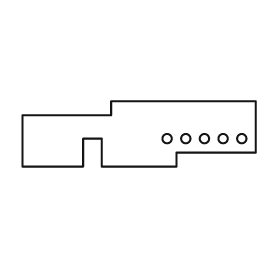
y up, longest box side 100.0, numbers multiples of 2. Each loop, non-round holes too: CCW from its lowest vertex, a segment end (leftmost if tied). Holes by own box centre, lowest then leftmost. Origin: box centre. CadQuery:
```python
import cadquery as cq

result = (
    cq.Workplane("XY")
    .moveTo(-50.0, -14.0)
    .lineTo(-24.0, -14.0)
    .lineTo(-24.0, -2.0)
    .lineTo(-16.0, -2.0)
    .lineTo(-16.0, -14.0)
    .lineTo(16.0, -14.0)
    .lineTo(16.0, -8.0)
    .lineTo(50.0, -8.0)
    .lineTo(50.0, 14.0)
    .lineTo(-12.0, 14.0)
    .lineTo(-12.0, 8.0)
    .lineTo(-50.0, 8.0)
    .close()
    .moveTo(12.0, -2.0)
    .circle(2.0)
    .moveTo(20.0, -2.0)
    .circle(2.0)
    .moveTo(28.0, -2.0)
    .circle(2.0)
    .moveTo(36.0, -2.0)
    .circle(2.0)
    .moveTo(44.0, -2.0)
    .circle(2.0)
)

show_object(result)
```